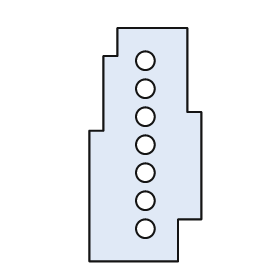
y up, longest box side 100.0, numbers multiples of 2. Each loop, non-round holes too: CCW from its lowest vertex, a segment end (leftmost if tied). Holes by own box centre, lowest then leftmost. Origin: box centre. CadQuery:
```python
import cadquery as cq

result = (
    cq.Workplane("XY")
    .moveTo(-24.0, -50.0)
    .lineTo(14.0, -50.0)
    .lineTo(14.0, -32.0)
    .lineTo(24.0, -32.0)
    .lineTo(24.0, 14.0)
    .lineTo(18.0, 14.0)
    .lineTo(18.0, 50.0)
    .lineTo(-12.0, 50.0)
    .lineTo(-12.0, 38.0)
    .lineTo(-18.0, 38.0)
    .lineTo(-18.0, 6.0)
    .lineTo(-24.0, 6.0)
    .close()
    .moveTo(0.0, -36.0)
    .circle(4.0)
    .moveTo(0.0, -24.0)
    .circle(4.0)
    .moveTo(0.0, -12.0)
    .circle(4.0)
    .moveTo(0.0, 0.0)
    .circle(4.0)
    .moveTo(0.0, 12.0)
    .circle(4.0)
    .moveTo(0.0, 24.0)
    .circle(4.0)
    .moveTo(0.0, 36.0)
    .circle(4.0)
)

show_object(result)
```